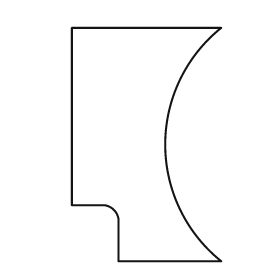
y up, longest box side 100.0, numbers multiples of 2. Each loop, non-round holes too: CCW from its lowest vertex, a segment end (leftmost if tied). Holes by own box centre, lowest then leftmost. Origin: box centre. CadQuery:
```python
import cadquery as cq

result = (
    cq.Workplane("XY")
    .moveTo(-12.0, -50.0)
    .lineTo(32.0, -50.0)
    .threePointArc((8.0, 0.0), (32.0, 50.0))
    .lineTo(-32.0, 50.0)
    .lineTo(-32.0, -26.0)
    .lineTo(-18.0, -26.0)
    .threePointArc((-14.0, -28.0), (-12.0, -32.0))
    .close()
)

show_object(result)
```